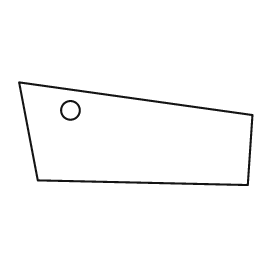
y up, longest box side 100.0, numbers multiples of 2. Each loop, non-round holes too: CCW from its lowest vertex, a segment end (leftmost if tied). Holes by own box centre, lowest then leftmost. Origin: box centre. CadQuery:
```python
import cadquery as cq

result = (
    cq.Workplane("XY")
    .moveTo(48.0, -22.0)
    .lineTo(50.0, 8.0)
    .lineTo(-50.0, 22.0)
    .lineTo(-42.0, -20.0)
    .close()
    .moveTo(-28.0, 10.0)
    .circle(4.0)
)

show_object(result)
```